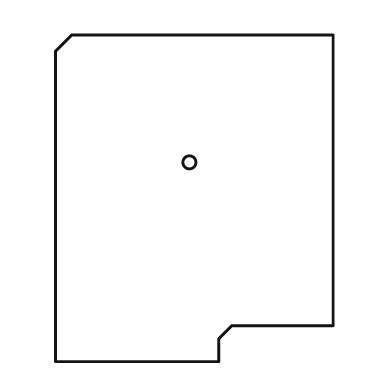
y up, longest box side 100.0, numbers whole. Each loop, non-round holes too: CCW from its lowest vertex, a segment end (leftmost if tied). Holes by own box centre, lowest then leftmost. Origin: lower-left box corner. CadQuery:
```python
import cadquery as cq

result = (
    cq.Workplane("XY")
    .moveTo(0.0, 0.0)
    .lineTo(50.0, 0.0)
    .lineTo(50.0, 7.0)
    .lineTo(54.0, 11.0)
    .lineTo(85.0, 11.0)
    .lineTo(85.0, 100.0)
    .lineTo(5.0, 100.0)
    .lineTo(0.0, 95.0)
    .close()
    .moveTo(41.0, 61.0)
    .circle(2.0)
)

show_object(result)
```